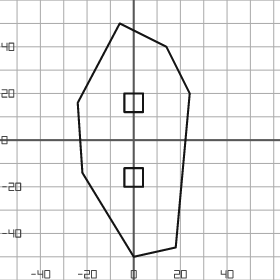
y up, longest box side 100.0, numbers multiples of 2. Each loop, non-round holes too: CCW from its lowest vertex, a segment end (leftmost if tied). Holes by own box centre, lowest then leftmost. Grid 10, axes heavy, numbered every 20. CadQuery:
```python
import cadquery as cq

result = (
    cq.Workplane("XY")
    .moveTo(0.0, -50.0)
    .lineTo(18.0, -46.0)
    .lineTo(24.0, 20.0)
    .lineTo(14.0, 40.0)
    .lineTo(-6.0, 50.0)
    .lineTo(-24.0, 16.0)
    .lineTo(-22.0, -14.0)
    .close()
    .moveTo(-4.0, -20.0)
    .lineTo(4.0, -20.0)
    .lineTo(4.0, -12.0)
    .lineTo(-4.0, -12.0)
    .close()
    .moveTo(-4.0, 12.0)
    .lineTo(4.0, 12.0)
    .lineTo(4.0, 20.0)
    .lineTo(-4.0, 20.0)
    .close()
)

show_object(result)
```